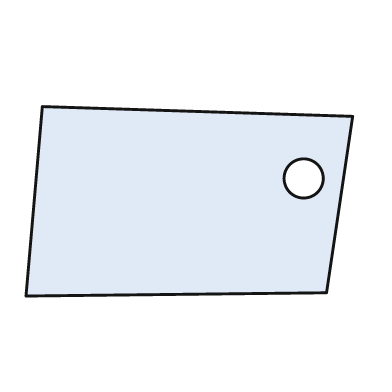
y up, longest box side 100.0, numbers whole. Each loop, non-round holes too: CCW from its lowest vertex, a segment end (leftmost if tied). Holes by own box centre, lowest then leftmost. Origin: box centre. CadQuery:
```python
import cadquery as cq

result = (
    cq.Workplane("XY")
    .moveTo(-50.0, -29.0)
    .lineTo(42.0, -28.0)
    .lineTo(50.0, 26.0)
    .lineTo(-45.0, 29.0)
    .close()
    .moveTo(35.0, 7.0)
    .circle(6.0)
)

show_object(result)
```